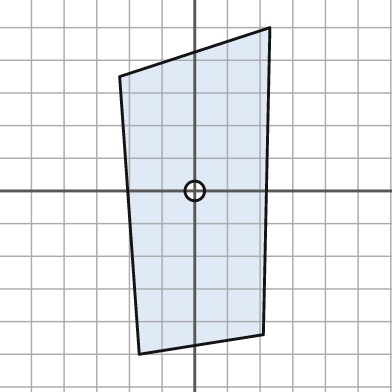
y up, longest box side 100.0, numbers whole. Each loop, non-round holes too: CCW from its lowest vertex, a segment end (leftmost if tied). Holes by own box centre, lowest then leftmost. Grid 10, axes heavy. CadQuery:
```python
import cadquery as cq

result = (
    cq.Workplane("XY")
    .moveTo(-17.0, -50.0)
    .lineTo(21.0, -44.0)
    .lineTo(23.0, 50.0)
    .lineTo(-23.0, 35.0)
    .close()
    .moveTo(0.0, 0.0)
    .circle(3.0)
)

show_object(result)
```